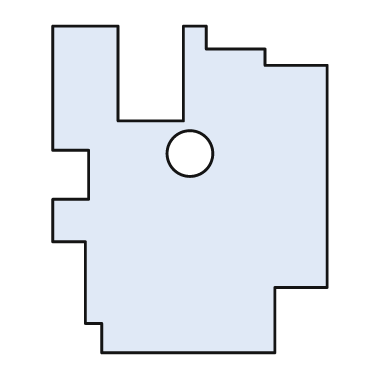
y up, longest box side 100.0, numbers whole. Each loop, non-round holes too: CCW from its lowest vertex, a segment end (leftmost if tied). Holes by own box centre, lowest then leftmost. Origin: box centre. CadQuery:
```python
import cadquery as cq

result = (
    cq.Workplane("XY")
    .moveTo(-27.0, -50.0)
    .lineTo(26.0, -50.0)
    .lineTo(26.0, -30.0)
    .lineTo(42.0, -30.0)
    .lineTo(42.0, 38.0)
    .lineTo(23.0, 38.0)
    .lineTo(23.0, 43.0)
    .lineTo(5.0, 43.0)
    .lineTo(5.0, 50.0)
    .lineTo(-2.0, 50.0)
    .lineTo(-2.0, 21.0)
    .lineTo(-22.0, 21.0)
    .lineTo(-22.0, 50.0)
    .lineTo(-42.0, 50.0)
    .lineTo(-42.0, 12.0)
    .lineTo(-31.0, 12.0)
    .lineTo(-31.0, -3.0)
    .lineTo(-42.0, -3.0)
    .lineTo(-42.0, -16.0)
    .lineTo(-32.0, -16.0)
    .lineTo(-32.0, -41.0)
    .lineTo(-27.0, -41.0)
    .close()
    .moveTo(0.0, 11.0)
    .circle(7.0)
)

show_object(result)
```